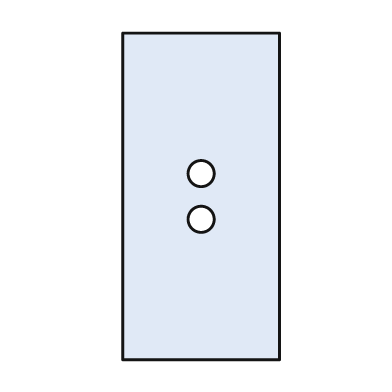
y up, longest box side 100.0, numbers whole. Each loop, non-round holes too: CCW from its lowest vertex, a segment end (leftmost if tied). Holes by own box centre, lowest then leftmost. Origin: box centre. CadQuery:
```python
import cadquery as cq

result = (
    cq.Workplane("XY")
    .moveTo(-24.0, -50.0)
    .lineTo(24.0, -50.0)
    .lineTo(24.0, 50.0)
    .lineTo(-24.0, 50.0)
    .close()
    .moveTo(0.0, -7.0)
    .circle(4.0)
    .moveTo(0.0, 7.0)
    .circle(4.0)
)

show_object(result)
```